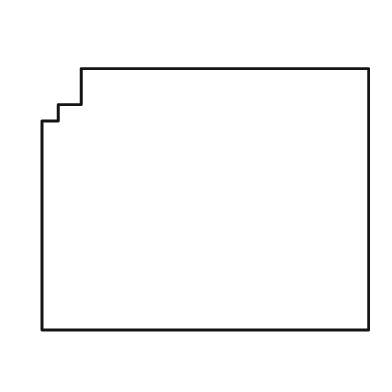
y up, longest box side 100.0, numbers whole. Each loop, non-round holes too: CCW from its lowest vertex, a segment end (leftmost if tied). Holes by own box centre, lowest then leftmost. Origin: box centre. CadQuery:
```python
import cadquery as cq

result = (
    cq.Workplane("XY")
    .moveTo(-50.0, -40.0)
    .lineTo(50.0, -40.0)
    .lineTo(50.0, 40.0)
    .lineTo(-38.0, 40.0)
    .lineTo(-38.0, 29.0)
    .lineTo(-45.0, 29.0)
    .lineTo(-45.0, 24.0)
    .lineTo(-50.0, 24.0)
    .close()
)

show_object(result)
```